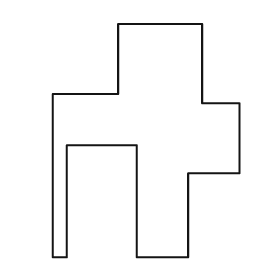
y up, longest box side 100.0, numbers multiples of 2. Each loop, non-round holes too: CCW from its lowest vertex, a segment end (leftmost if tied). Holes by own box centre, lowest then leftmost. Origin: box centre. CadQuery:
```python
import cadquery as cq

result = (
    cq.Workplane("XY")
    .moveTo(-40.0, -50.0)
    .lineTo(-34.0, -50.0)
    .lineTo(-34.0, -2.0)
    .lineTo(-4.0, -2.0)
    .lineTo(-4.0, -50.0)
    .lineTo(18.0, -50.0)
    .lineTo(18.0, -14.0)
    .lineTo(40.0, -14.0)
    .lineTo(40.0, 16.0)
    .lineTo(24.0, 16.0)
    .lineTo(24.0, 50.0)
    .lineTo(-12.0, 50.0)
    .lineTo(-12.0, 20.0)
    .lineTo(-40.0, 20.0)
    .close()
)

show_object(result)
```